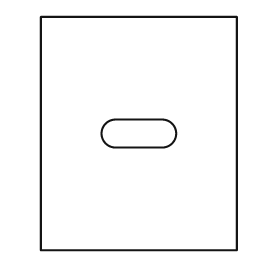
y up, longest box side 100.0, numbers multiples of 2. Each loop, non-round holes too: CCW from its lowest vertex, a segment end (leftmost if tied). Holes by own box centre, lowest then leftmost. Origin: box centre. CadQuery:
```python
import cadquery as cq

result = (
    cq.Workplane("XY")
    .moveTo(-42.0, -50.0)
    .lineTo(42.0, -50.0)
    .lineTo(42.0, 50.0)
    .lineTo(-42.0, 50.0)
    .close()
    .moveTo(-10.0, -6.0)
    .lineTo(10.0, -6.0)
    .threePointArc((16.0, 0.0), (10.0, 6.0))
    .lineTo(-10.0, 6.0)
    .threePointArc((-16.0, 0.0), (-10.0, -6.0))
    .close()
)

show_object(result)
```